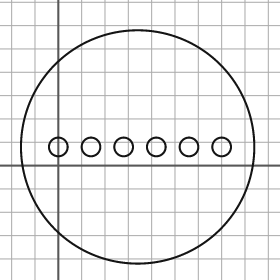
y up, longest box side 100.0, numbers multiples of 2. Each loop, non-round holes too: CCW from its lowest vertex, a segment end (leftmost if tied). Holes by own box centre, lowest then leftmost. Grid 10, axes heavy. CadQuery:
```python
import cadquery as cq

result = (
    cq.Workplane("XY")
    .moveTo(34.0, 8.0)
    .circle(50.0)
    .moveTo(0.0, 8.0)
    .circle(4.0)
    .moveTo(14.0, 8.0)
    .circle(4.0)
    .moveTo(28.0, 8.0)
    .circle(4.0)
    .moveTo(42.0, 8.0)
    .circle(4.0)
    .moveTo(56.0, 8.0)
    .circle(4.0)
    .moveTo(70.0, 8.0)
    .circle(4.0)
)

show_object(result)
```